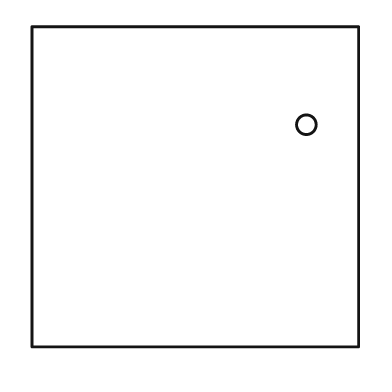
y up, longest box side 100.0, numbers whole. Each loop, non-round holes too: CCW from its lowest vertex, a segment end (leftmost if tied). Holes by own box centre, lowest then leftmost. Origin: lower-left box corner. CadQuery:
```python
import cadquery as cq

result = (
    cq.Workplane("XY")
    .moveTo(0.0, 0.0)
    .lineTo(100.0, 0.0)
    .lineTo(100.0, 98.0)
    .lineTo(0.0, 98.0)
    .close()
    .moveTo(84.0, 68.0)
    .circle(3.0)
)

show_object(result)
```